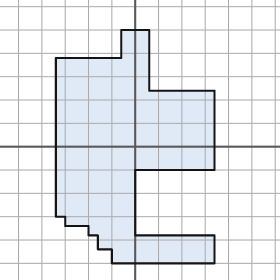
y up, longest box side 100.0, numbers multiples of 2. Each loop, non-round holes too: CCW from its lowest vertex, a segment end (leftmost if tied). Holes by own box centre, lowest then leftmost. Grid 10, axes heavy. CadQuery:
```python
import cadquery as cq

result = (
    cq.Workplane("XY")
    .moveTo(-10.0, -50.0)
    .lineTo(34.0, -50.0)
    .lineTo(34.0, -38.0)
    .lineTo(0.0, -38.0)
    .lineTo(0.0, -10.0)
    .lineTo(34.0, -10.0)
    .lineTo(34.0, 24.0)
    .lineTo(6.0, 24.0)
    .lineTo(6.0, 50.0)
    .lineTo(-6.0, 50.0)
    .lineTo(-6.0, 38.0)
    .lineTo(-34.0, 38.0)
    .lineTo(-34.0, -30.0)
    .lineTo(-30.0, -30.0)
    .lineTo(-30.0, -34.0)
    .lineTo(-20.0, -34.0)
    .lineTo(-20.0, -38.0)
    .lineTo(-16.0, -38.0)
    .lineTo(-16.0, -44.0)
    .lineTo(-10.0, -44.0)
    .close()
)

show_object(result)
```